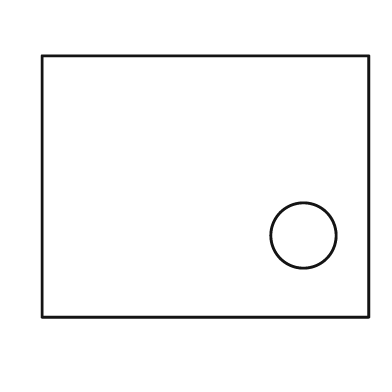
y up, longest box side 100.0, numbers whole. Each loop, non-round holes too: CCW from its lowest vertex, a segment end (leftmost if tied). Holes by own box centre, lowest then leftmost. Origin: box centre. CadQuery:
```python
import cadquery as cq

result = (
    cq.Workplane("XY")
    .moveTo(-50.0, -40.0)
    .lineTo(50.0, -40.0)
    .lineTo(50.0, 40.0)
    .lineTo(-50.0, 40.0)
    .close()
    .moveTo(30.0, -15.0)
    .circle(10.0)
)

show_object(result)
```